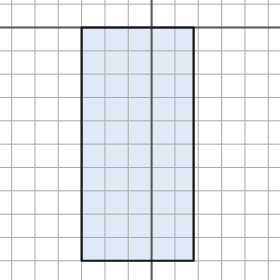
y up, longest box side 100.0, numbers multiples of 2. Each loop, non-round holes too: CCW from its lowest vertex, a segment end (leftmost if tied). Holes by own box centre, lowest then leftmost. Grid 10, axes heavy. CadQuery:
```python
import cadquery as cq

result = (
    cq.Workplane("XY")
    .moveTo(-30.0, -100.0)
    .lineTo(18.0, -100.0)
    .lineTo(18.0, 0.0)
    .lineTo(-30.0, 0.0)
    .close()
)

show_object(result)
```